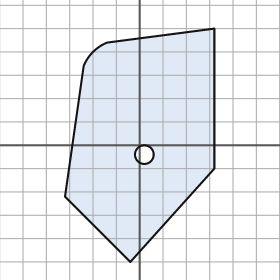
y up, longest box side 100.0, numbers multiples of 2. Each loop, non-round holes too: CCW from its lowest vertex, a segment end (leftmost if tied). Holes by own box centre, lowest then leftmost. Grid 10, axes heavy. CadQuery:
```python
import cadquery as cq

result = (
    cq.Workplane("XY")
    .moveTo(-4.0, -50.0)
    .lineTo(32.0, -10.0)
    .lineTo(32.0, 50.0)
    .lineTo(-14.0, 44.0)
    .threePointArc((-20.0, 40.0), (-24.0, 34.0))
    .lineTo(-32.0, -22.0)
    .close()
    .moveTo(2.0, -4.0)
    .circle(4.0)
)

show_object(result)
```